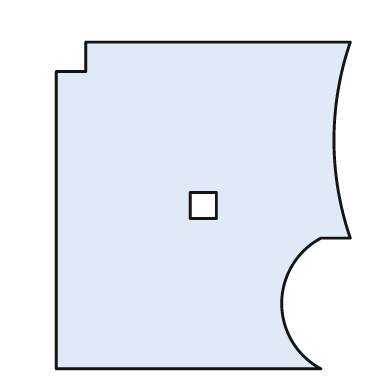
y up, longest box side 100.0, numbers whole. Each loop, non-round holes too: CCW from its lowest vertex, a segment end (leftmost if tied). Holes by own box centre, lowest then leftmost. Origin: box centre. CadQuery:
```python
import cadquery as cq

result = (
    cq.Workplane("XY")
    .moveTo(-45.0, -50.0)
    .lineTo(36.0, -50.0)
    .threePointArc((24.0, -30.0), (36.0, -10.0))
    .lineTo(45.0, -10.0)
    .threePointArc((40.0, 20.0), (45.0, 50.0))
    .lineTo(-36.0, 50.0)
    .lineTo(-36.0, 41.0)
    .lineTo(-45.0, 41.0)
    .close()
    .moveTo(-4.0, -4.0)
    .lineTo(4.0, -4.0)
    .lineTo(4.0, 4.0)
    .lineTo(-4.0, 4.0)
    .close()
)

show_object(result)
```